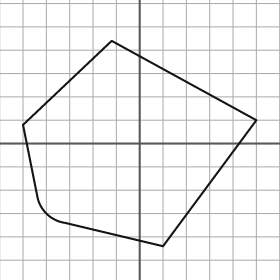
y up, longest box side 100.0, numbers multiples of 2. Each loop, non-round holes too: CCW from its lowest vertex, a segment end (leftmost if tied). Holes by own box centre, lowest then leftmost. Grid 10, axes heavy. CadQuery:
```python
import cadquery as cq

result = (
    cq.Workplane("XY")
    .moveTo(10.0, -44.0)
    .lineTo(50.0, 10.0)
    .lineTo(-12.0, 44.0)
    .lineTo(-50.0, 8.0)
    .lineTo(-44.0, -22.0)
    .threePointArc((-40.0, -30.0), (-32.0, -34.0))
    .close()
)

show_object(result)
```